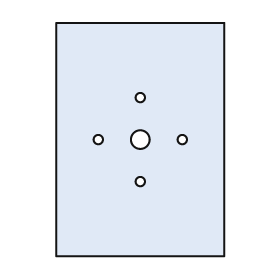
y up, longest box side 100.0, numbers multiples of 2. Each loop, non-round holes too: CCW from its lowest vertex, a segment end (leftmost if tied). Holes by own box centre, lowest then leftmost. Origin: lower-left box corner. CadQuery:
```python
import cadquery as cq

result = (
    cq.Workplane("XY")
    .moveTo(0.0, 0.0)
    .lineTo(72.0, 0.0)
    .lineTo(72.0, 100.0)
    .lineTo(0.0, 100.0)
    .close()
    .moveTo(36.0, 32.0)
    .circle(2.0)
    .moveTo(18.0, 50.0)
    .circle(2.0)
    .moveTo(36.0, 50.0)
    .circle(4.0)
    .moveTo(54.0, 50.0)
    .circle(2.0)
    .moveTo(36.0, 68.0)
    .circle(2.0)
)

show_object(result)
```